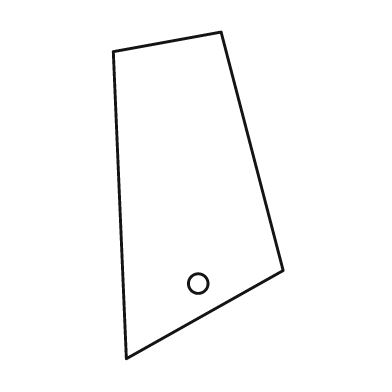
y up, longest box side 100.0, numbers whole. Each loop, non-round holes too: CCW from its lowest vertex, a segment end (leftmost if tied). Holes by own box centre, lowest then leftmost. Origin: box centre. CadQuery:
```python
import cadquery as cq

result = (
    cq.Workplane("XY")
    .moveTo(-22.0, -50.0)
    .lineTo(26.0, -23.0)
    .lineTo(7.0, 50.0)
    .lineTo(-26.0, 44.0)
    .close()
    .moveTo(0.0, -27.0)
    .circle(3.0)
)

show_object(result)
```